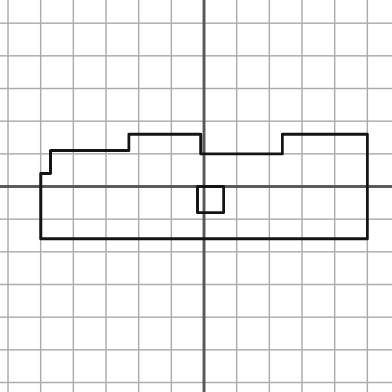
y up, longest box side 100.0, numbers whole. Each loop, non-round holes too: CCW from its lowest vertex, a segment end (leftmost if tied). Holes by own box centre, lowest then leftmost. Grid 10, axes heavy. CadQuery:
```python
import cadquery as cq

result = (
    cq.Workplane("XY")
    .moveTo(-50.0, -16.0)
    .lineTo(50.0, -16.0)
    .lineTo(50.0, 16.0)
    .lineTo(24.0, 16.0)
    .lineTo(24.0, 10.0)
    .lineTo(-1.0, 10.0)
    .lineTo(-1.0, 16.0)
    .lineTo(-23.0, 16.0)
    .lineTo(-23.0, 11.0)
    .lineTo(-47.0, 11.0)
    .lineTo(-47.0, 4.0)
    .lineTo(-50.0, 4.0)
    .close()
    .moveTo(-2.0, -8.0)
    .lineTo(6.0, -8.0)
    .lineTo(6.0, 0.0)
    .lineTo(-2.0, 0.0)
    .close()
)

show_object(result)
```